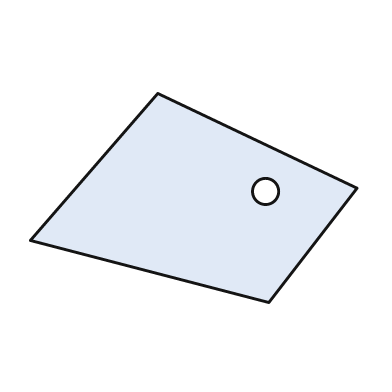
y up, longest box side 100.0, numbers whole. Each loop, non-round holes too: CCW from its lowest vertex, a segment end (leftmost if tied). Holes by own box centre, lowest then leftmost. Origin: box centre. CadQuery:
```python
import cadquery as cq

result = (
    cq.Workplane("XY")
    .moveTo(23.0, -32.0)
    .lineTo(50.0, 3.0)
    .lineTo(-11.0, 32.0)
    .lineTo(-50.0, -13.0)
    .close()
    .moveTo(22.0, 2.0)
    .circle(4.0)
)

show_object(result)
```